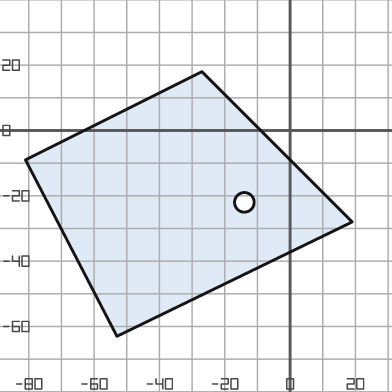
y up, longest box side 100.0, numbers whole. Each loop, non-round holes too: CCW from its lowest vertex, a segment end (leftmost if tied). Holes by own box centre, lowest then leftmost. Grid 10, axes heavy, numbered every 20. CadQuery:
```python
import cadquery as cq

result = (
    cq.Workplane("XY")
    .moveTo(-53.0, -63.0)
    .lineTo(19.0, -28.0)
    .lineTo(-27.0, 18.0)
    .lineTo(-81.0, -9.0)
    .close()
    .moveTo(-14.0, -22.0)
    .circle(3.0)
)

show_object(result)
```